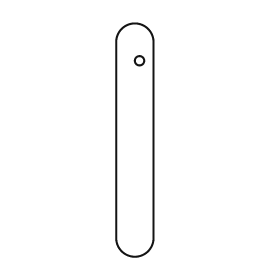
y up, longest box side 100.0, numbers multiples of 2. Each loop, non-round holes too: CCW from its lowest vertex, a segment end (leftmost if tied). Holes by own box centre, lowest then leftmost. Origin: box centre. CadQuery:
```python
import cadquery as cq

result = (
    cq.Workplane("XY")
    .moveTo(-8.0, -42.0)
    .threePointArc((0.0, -50.0), (8.0, -42.0))
    .lineTo(8.0, 42.0)
    .threePointArc((0.0, 50.0), (-8.0, 42.0))
    .close()
    .moveTo(2.0, 34.0)
    .circle(2.0)
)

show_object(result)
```